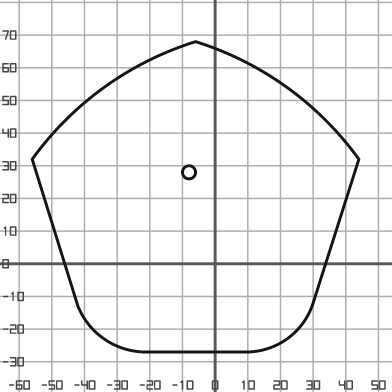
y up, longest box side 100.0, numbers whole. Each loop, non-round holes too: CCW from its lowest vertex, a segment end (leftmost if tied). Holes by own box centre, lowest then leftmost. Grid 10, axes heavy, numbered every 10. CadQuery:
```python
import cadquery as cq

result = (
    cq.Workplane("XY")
    .moveTo(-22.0, -27.0)
    .lineTo(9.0, -27.0)
    .threePointArc((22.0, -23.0), (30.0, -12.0))
    .lineTo(44.0, 32.0)
    .threePointArc((22.0, 54.0), (-6.0, 68.0))
    .threePointArc((-34.0, 54.0), (-56.0, 32.0))
    .lineTo(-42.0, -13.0)
    .threePointArc((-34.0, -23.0), (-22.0, -27.0))
    .close()
    .moveTo(-8.0, 28.0)
    .circle(2.0)
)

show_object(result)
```